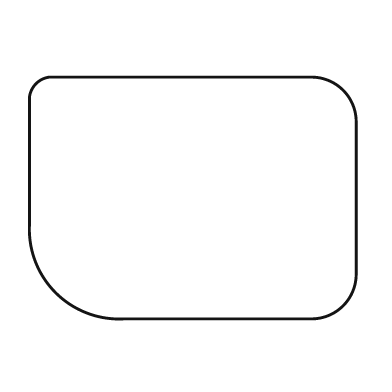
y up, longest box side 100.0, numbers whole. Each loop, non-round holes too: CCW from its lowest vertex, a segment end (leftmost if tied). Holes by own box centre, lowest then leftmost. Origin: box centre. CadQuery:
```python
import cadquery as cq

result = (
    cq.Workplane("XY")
    .moveTo(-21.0, -37.0)
    .lineTo(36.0, -37.0)
    .threePointArc((46.0, -33.0), (50.0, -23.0))
    .lineTo(50.0, 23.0)
    .threePointArc((46.0, 33.0), (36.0, 37.0))
    .lineTo(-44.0, 37.0)
    .threePointArc((-48.0, 35.0), (-50.0, 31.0))
    .lineTo(-50.0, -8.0)
    .threePointArc((-42.0, -29.0), (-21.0, -37.0))
    .close()
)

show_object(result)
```